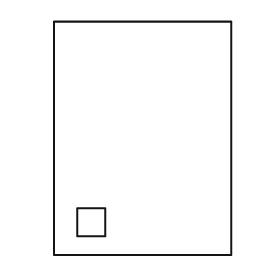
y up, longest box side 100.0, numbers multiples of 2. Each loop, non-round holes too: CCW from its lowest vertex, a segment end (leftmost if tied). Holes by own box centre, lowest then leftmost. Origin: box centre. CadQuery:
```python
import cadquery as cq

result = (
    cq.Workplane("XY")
    .moveTo(-38.0, -50.0)
    .lineTo(38.0, -50.0)
    .lineTo(38.0, 50.0)
    .lineTo(-38.0, 50.0)
    .close()
    .moveTo(-28.0, -42.0)
    .lineTo(-16.0, -42.0)
    .lineTo(-16.0, -30.0)
    .lineTo(-28.0, -30.0)
    .close()
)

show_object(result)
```